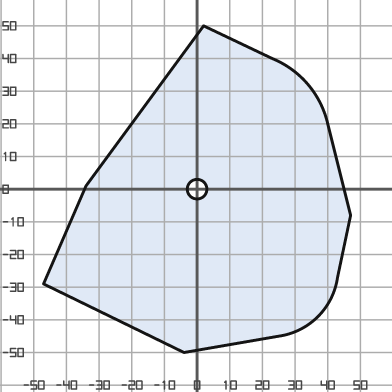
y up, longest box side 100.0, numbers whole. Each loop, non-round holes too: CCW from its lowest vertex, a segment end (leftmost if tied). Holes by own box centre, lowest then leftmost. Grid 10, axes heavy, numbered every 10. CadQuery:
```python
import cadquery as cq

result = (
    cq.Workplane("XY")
    .moveTo(-4.0, -50.0)
    .lineTo(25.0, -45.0)
    .threePointArc((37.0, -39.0), (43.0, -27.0))
    .lineTo(47.0, -8.0)
    .lineTo(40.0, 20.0)
    .threePointArc((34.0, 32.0), (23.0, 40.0))
    .lineTo(2.0, 50.0)
    .lineTo(-34.0, 1.0)
    .lineTo(-47.0, -29.0)
    .close()
    .moveTo(0.0, 0.0)
    .circle(3.0)
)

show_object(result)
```